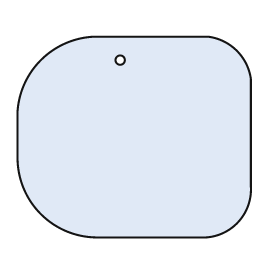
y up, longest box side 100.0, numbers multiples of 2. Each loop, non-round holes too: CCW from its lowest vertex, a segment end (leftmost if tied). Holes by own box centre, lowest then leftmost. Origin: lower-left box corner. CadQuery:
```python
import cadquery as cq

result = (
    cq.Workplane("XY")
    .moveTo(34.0, 0.0)
    .lineTo(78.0, 0.0)
    .threePointArc((94.0, 6.0), (100.0, 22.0))
    .lineTo(100.0, 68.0)
    .threePointArc((94.0, 80.0), (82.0, 86.0))
    .lineTo(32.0, 86.0)
    .threePointArc((10.0, 76.0), (0.0, 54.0))
    .lineTo(0.0, 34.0)
    .threePointArc((10.0, 10.0), (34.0, 0.0))
    .close()
    .moveTo(44.0, 76.0)
    .circle(2.0)
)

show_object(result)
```